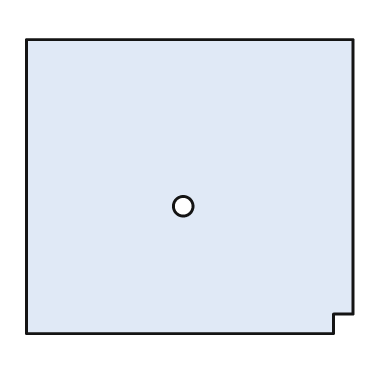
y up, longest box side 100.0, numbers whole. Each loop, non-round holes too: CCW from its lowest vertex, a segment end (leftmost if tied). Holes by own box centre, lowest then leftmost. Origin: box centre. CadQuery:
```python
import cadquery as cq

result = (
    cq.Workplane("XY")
    .moveTo(-50.0, -45.0)
    .lineTo(44.0, -45.0)
    .lineTo(44.0, -39.0)
    .lineTo(50.0, -39.0)
    .lineTo(50.0, 45.0)
    .lineTo(-50.0, 45.0)
    .close()
    .moveTo(-2.0, -6.0)
    .circle(3.0)
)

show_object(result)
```